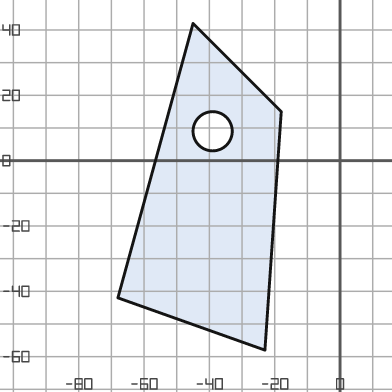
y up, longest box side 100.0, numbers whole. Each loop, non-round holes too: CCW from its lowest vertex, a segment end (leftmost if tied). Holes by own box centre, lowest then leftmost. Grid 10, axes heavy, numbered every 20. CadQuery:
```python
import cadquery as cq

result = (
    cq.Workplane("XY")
    .moveTo(-23.0, -58.0)
    .lineTo(-18.0, 15.0)
    .lineTo(-45.0, 42.0)
    .lineTo(-68.0, -42.0)
    .close()
    .moveTo(-39.0, 9.0)
    .circle(6.0)
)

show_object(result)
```